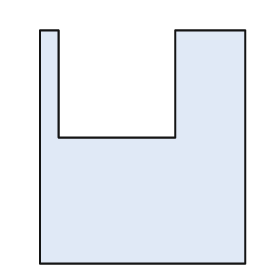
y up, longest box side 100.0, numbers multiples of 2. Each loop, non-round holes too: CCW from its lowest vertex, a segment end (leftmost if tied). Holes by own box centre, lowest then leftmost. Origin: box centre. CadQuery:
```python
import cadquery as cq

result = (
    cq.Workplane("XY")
    .moveTo(-44.0, -50.0)
    .lineTo(44.0, -50.0)
    .lineTo(44.0, 50.0)
    .lineTo(14.0, 50.0)
    .lineTo(14.0, 4.0)
    .lineTo(-36.0, 4.0)
    .lineTo(-36.0, 50.0)
    .lineTo(-44.0, 50.0)
    .close()
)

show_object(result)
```